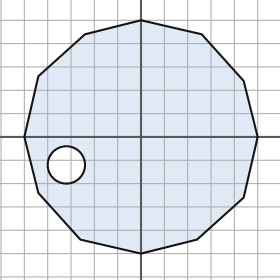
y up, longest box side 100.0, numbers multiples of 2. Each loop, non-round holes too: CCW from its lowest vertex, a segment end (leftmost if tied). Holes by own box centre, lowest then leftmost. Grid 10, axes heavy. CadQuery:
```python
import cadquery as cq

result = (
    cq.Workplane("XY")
    .moveTo(0.0, -50.0)
    .lineTo(24.0, -44.0)
    .lineTo(44.0, -26.0)
    .lineTo(50.0, 0.0)
    .lineTo(44.0, 24.0)
    .lineTo(26.0, 44.0)
    .lineTo(0.0, 50.0)
    .lineTo(-24.0, 44.0)
    .lineTo(-44.0, 26.0)
    .lineTo(-50.0, 0.0)
    .lineTo(-44.0, -24.0)
    .lineTo(-26.0, -44.0)
    .close()
    .moveTo(-32.0, -12.0)
    .circle(8.0)
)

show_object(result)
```